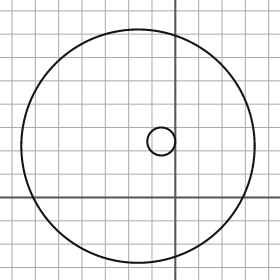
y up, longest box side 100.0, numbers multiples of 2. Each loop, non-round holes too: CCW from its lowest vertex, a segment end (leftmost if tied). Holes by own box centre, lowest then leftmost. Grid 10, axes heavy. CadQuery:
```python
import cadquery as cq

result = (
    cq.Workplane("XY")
    .moveTo(-16.0, 22.0)
    .circle(50.0)
    .moveTo(-6.0, 24.0)
    .circle(6.0)
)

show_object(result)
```